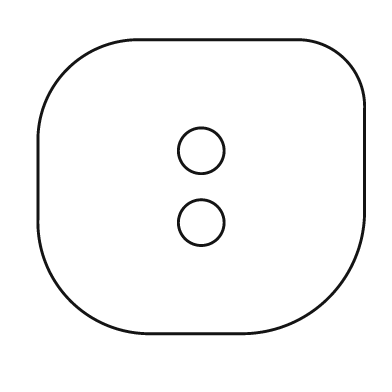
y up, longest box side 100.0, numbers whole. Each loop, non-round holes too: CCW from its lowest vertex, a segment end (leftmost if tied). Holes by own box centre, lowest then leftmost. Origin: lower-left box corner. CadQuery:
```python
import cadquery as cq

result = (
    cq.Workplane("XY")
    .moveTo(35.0, 0.0)
    .lineTo(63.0, 0.0)
    .threePointArc((89.0, 11.0), (100.0, 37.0))
    .lineTo(100.0, 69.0)
    .threePointArc((94.0, 84.0), (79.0, 90.0))
    .lineTo(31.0, 90.0)
    .threePointArc((9.0, 81.0), (0.0, 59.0))
    .lineTo(0.0, 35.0)
    .threePointArc((10.0, 10.0), (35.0, 0.0))
    .close()
    .moveTo(50.0, 34.0)
    .circle(7.0)
    .moveTo(50.0, 56.0)
    .circle(7.0)
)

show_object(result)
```